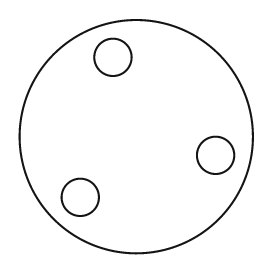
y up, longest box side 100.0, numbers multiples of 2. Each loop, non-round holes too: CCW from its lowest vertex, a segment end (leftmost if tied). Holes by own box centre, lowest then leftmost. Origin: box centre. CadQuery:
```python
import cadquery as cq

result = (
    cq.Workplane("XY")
    .moveTo(0.0, 0.0)
    .circle(50.0)
    .moveTo(-24.0, -26.0)
    .circle(8.0)
    .moveTo(34.0, -8.0)
    .circle(8.0)
    .moveTo(-10.0, 34.0)
    .circle(8.0)
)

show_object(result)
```